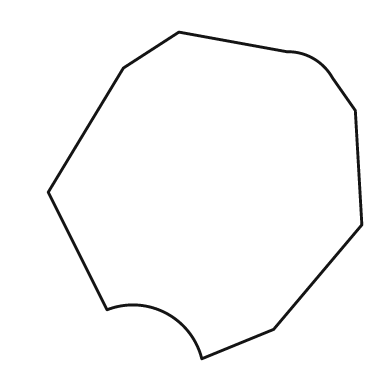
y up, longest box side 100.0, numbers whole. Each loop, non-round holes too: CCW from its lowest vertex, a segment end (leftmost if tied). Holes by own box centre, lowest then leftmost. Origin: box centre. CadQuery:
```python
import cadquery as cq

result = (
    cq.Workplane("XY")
    .moveTo(-1.0, -50.0)
    .lineTo(21.0, -41.0)
    .lineTo(48.0, -9.0)
    .lineTo(46.0, 26.0)
    .lineTo(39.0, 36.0)
    .threePointArc((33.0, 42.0), (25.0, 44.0))
    .lineTo(-8.0, 50.0)
    .lineTo(-25.0, 39.0)
    .lineTo(-48.0, 1.0)
    .lineTo(-30.0, -35.0)
    .threePointArc((-12.0, -36.0), (-1.0, -50.0))
    .close()
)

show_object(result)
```